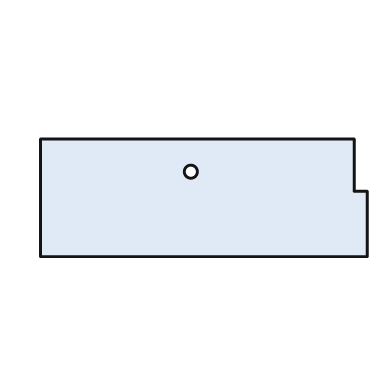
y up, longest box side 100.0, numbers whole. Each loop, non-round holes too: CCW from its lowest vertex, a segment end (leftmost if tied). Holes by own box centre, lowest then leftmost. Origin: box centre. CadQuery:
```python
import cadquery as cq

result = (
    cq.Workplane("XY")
    .moveTo(-50.0, -18.0)
    .lineTo(50.0, -18.0)
    .lineTo(50.0, 2.0)
    .lineTo(46.0, 2.0)
    .lineTo(46.0, 18.0)
    .lineTo(-50.0, 18.0)
    .close()
    .moveTo(-4.0, 8.0)
    .circle(2.0)
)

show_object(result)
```